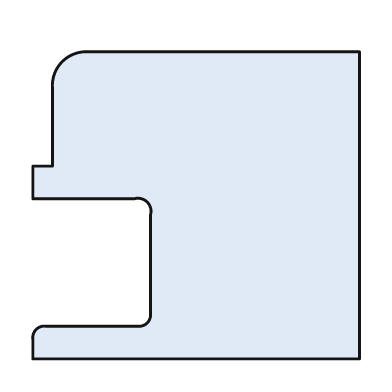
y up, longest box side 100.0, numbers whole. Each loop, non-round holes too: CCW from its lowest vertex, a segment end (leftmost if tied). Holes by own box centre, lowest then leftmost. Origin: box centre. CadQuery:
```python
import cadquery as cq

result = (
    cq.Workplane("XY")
    .moveTo(-50.0, -47.0)
    .lineTo(50.0, -47.0)
    .lineTo(50.0, 47.0)
    .lineTo(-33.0, 47.0)
    .threePointArc((-41.0, 44.0), (-44.0, 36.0))
    .lineTo(-44.0, 12.0)
    .lineTo(-50.0, 12.0)
    .lineTo(-50.0, 2.0)
    .lineTo(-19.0, 2.0)
    .threePointArc((-15.0, 1.0), (-14.0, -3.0))
    .lineTo(-14.0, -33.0)
    .threePointArc((-15.0, -36.0), (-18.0, -37.0))
    .lineTo(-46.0, -37.0)
    .threePointArc((-49.0, -38.0), (-50.0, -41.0))
    .close()
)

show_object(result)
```